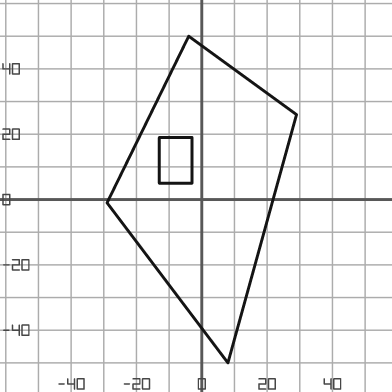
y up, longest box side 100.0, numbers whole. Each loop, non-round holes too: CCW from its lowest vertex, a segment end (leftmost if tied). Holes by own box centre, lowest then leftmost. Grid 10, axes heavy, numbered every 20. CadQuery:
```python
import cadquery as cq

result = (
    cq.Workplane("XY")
    .moveTo(8.0, -50.0)
    .lineTo(29.0, 26.0)
    .lineTo(-4.0, 50.0)
    .lineTo(-29.0, -1.0)
    .close()
    .moveTo(-13.0, 5.0)
    .lineTo(-3.0, 5.0)
    .lineTo(-3.0, 19.0)
    .lineTo(-13.0, 19.0)
    .close()
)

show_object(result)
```